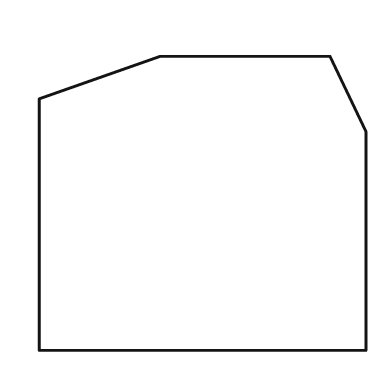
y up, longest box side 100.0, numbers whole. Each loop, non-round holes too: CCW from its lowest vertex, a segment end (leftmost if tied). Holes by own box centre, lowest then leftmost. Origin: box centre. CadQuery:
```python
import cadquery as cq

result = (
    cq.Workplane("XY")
    .moveTo(-50.0, -45.0)
    .lineTo(50.0, -45.0)
    .lineTo(50.0, 22.0)
    .lineTo(39.0, 45.0)
    .lineTo(-13.0, 45.0)
    .lineTo(-50.0, 32.0)
    .close()
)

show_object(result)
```